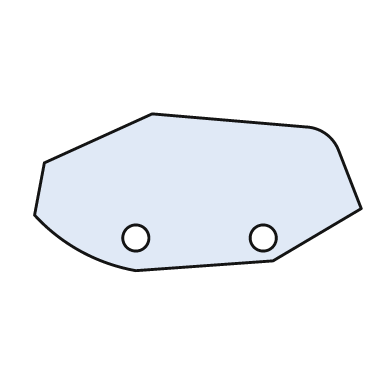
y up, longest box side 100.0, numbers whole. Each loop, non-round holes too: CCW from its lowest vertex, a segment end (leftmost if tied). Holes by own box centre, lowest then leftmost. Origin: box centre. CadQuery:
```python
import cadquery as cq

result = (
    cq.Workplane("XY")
    .moveTo(-19.0, -24.0)
    .lineTo(23.0, -21.0)
    .lineTo(50.0, -5.0)
    .lineTo(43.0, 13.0)
    .threePointArc((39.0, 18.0), (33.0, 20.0))
    .lineTo(-14.0, 24.0)
    .lineTo(-47.0, 9.0)
    .lineTo(-50.0, -7.0)
    .threePointArc((-36.0, -18.0), (-19.0, -24.0))
    .close()
    .moveTo(-19.0, -14.0)
    .circle(4.0)
    .moveTo(20.0, -14.0)
    .circle(4.0)
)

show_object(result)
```